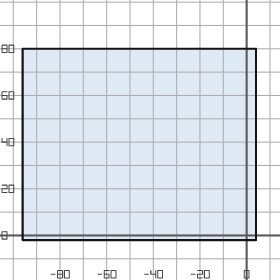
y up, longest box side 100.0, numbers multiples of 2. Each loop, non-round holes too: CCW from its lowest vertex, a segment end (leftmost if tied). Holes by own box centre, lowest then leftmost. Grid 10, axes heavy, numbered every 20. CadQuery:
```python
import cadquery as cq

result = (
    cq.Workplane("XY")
    .moveTo(-96.0, -2.0)
    .lineTo(4.0, -2.0)
    .lineTo(4.0, 80.0)
    .lineTo(-96.0, 80.0)
    .close()
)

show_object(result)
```